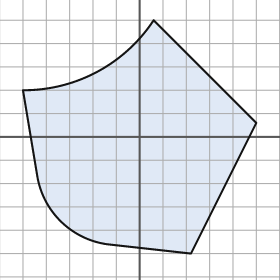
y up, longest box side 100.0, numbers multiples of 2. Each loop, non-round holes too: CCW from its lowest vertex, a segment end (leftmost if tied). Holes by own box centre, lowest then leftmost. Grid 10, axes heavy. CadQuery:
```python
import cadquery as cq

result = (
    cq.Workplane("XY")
    .moveTo(22.0, -50.0)
    .lineTo(50.0, 6.0)
    .lineTo(6.0, 50.0)
    .threePointArc((-18.0, 28.0), (-50.0, 20.0))
    .lineTo(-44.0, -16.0)
    .threePointArc((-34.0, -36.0), (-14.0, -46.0))
    .close()
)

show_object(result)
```